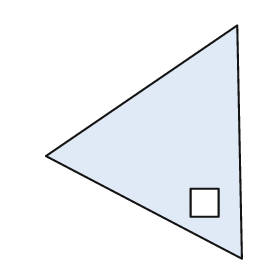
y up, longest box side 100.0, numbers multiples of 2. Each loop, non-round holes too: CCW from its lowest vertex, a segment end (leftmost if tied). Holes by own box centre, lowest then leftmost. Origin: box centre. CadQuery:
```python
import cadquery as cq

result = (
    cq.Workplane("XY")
    .moveTo(42.0, -50.0)
    .lineTo(40.0, 50.0)
    .lineTo(-42.0, -6.0)
    .close()
    .moveTo(20.0, -32.0)
    .lineTo(32.0, -32.0)
    .lineTo(32.0, -20.0)
    .lineTo(20.0, -20.0)
    .close()
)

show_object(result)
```